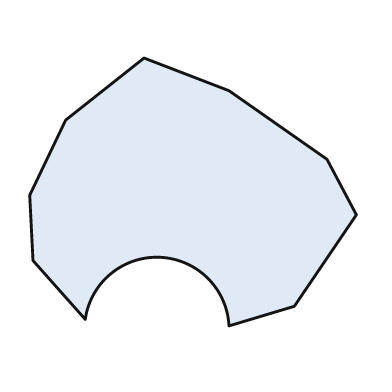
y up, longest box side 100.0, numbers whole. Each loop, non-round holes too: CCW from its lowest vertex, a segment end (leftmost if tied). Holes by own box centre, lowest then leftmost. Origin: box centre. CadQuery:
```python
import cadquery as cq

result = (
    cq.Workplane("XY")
    .moveTo(11.0, -41.0)
    .lineTo(31.0, -35.0)
    .lineTo(50.0, -7.0)
    .lineTo(41.0, 10.0)
    .lineTo(11.0, 31.0)
    .lineTo(-15.0, 41.0)
    .lineTo(-39.0, 22.0)
    .lineTo(-50.0, -1.0)
    .lineTo(-49.0, -21.0)
    .lineTo(-33.0, -39.0)
    .threePointArc((-10.0, -20.0), (11.0, -41.0))
    .close()
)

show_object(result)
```